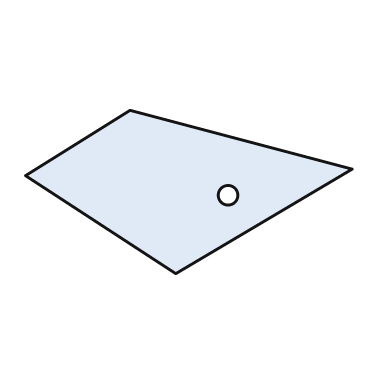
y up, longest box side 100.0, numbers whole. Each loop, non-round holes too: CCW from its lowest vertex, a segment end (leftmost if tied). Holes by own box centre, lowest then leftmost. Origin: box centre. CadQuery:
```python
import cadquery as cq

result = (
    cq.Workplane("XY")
    .moveTo(-4.0, -25.0)
    .lineTo(50.0, 7.0)
    .lineTo(-18.0, 25.0)
    .lineTo(-50.0, 5.0)
    .close()
    .moveTo(12.0, -1.0)
    .circle(3.0)
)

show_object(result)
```